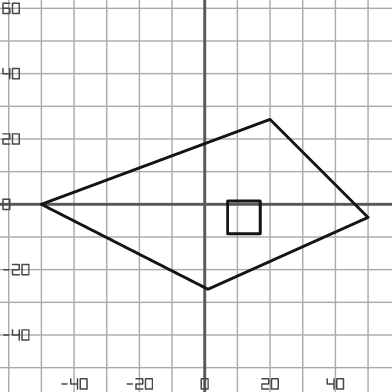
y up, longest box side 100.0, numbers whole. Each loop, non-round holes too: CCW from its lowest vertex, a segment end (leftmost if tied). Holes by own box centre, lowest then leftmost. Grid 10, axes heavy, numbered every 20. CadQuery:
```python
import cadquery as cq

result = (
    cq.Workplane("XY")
    .moveTo(1.0, -26.0)
    .lineTo(50.0, -4.0)
    .lineTo(20.0, 26.0)
    .lineTo(-50.0, 0.0)
    .close()
    .moveTo(7.0, -9.0)
    .lineTo(17.0, -9.0)
    .lineTo(17.0, 1.0)
    .lineTo(7.0, 1.0)
    .close()
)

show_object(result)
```